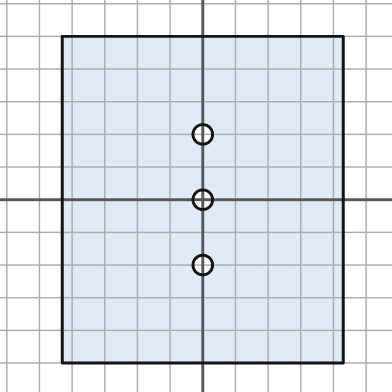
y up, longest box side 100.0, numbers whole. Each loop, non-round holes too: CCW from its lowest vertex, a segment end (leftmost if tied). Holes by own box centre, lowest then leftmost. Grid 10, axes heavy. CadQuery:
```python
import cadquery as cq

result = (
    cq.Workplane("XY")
    .moveTo(-43.0, -50.0)
    .lineTo(43.0, -50.0)
    .lineTo(43.0, 50.0)
    .lineTo(-43.0, 50.0)
    .close()
    .moveTo(0.0, -20.0)
    .circle(3.0)
    .moveTo(0.0, 0.0)
    .circle(3.0)
    .moveTo(0.0, 20.0)
    .circle(3.0)
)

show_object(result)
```